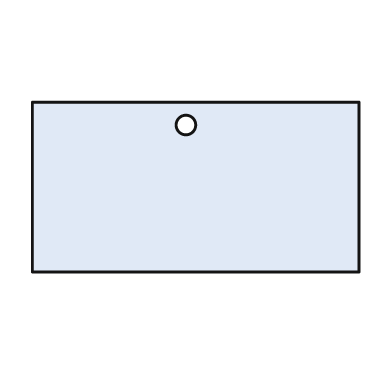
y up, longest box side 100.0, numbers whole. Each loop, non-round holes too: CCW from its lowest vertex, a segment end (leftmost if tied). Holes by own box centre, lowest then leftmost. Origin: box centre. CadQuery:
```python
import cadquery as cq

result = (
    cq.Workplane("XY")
    .moveTo(-50.0, -26.0)
    .lineTo(50.0, -26.0)
    .lineTo(50.0, 26.0)
    .lineTo(-50.0, 26.0)
    .close()
    .moveTo(-3.0, 19.0)
    .circle(3.0)
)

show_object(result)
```